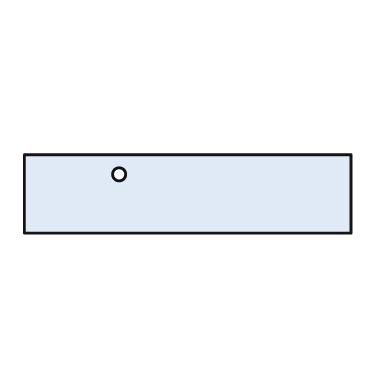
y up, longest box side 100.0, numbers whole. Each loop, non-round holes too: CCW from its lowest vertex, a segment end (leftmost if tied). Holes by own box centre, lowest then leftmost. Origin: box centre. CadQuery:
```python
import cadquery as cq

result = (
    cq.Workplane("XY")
    .moveTo(-50.0, -12.0)
    .lineTo(50.0, -12.0)
    .lineTo(50.0, 12.0)
    .lineTo(-50.0, 12.0)
    .close()
    .moveTo(-21.0, 6.0)
    .circle(2.0)
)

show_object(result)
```